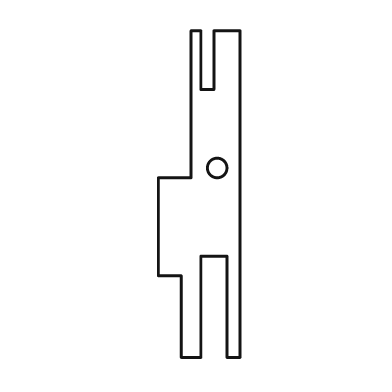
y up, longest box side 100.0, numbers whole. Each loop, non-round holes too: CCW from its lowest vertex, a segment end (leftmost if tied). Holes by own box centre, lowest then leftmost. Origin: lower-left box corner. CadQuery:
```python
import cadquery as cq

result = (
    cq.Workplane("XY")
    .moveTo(7.0, 0.0)
    .lineTo(13.0, 0.0)
    .lineTo(13.0, 31.0)
    .lineTo(21.0, 31.0)
    .lineTo(21.0, 0.0)
    .lineTo(25.0, 0.0)
    .lineTo(25.0, 100.0)
    .lineTo(17.0, 100.0)
    .lineTo(17.0, 82.0)
    .lineTo(13.0, 82.0)
    .lineTo(13.0, 100.0)
    .lineTo(10.0, 100.0)
    .lineTo(10.0, 55.0)
    .lineTo(0.0, 55.0)
    .lineTo(0.0, 25.0)
    .lineTo(7.0, 25.0)
    .close()
    .moveTo(18.0, 58.0)
    .circle(3.0)
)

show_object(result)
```